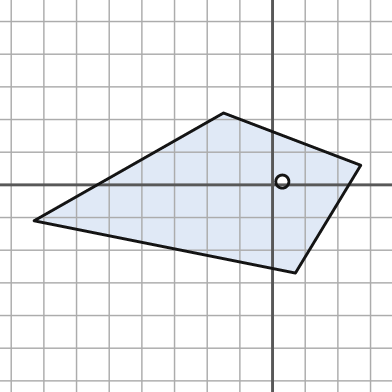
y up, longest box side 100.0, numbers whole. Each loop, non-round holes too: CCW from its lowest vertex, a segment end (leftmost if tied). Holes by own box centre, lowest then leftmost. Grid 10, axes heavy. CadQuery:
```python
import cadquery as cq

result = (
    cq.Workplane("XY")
    .moveTo(7.0, -27.0)
    .lineTo(27.0, 6.0)
    .lineTo(-15.0, 22.0)
    .lineTo(-73.0, -11.0)
    .close()
    .moveTo(3.0, 1.0)
    .circle(2.0)
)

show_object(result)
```